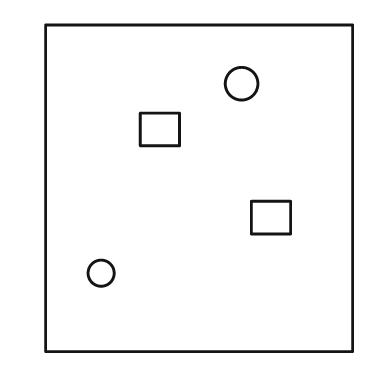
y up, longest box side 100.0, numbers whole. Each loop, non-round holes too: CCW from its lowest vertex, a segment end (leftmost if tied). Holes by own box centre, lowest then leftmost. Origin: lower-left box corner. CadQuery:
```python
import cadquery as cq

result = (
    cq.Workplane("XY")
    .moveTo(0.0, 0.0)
    .lineTo(94.0, 0.0)
    .lineTo(94.0, 100.0)
    .lineTo(0.0, 100.0)
    .close()
    .moveTo(17.0, 24.0)
    .circle(4.0)
    .moveTo(63.0, 36.0)
    .lineTo(75.0, 36.0)
    .lineTo(75.0, 46.0)
    .lineTo(63.0, 46.0)
    .close()
    .moveTo(29.0, 63.0)
    .lineTo(41.0, 63.0)
    .lineTo(41.0, 73.0)
    .lineTo(29.0, 73.0)
    .close()
    .moveTo(60.0, 82.0)
    .circle(5.0)
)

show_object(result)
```